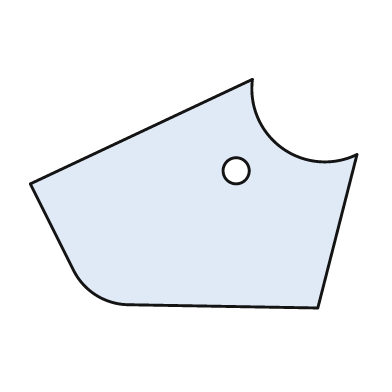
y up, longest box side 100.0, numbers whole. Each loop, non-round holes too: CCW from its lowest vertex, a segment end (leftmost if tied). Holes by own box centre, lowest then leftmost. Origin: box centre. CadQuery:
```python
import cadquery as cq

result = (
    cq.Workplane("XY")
    .moveTo(38.0, -35.0)
    .lineTo(50.0, 12.0)
    .threePointArc((27.0, 14.0), (18.0, 35.0))
    .lineTo(-50.0, 3.0)
    .lineTo(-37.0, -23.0)
    .threePointArc((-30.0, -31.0), (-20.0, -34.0))
    .close()
    .moveTo(13.0, 7.0)
    .circle(4.0)
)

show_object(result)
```